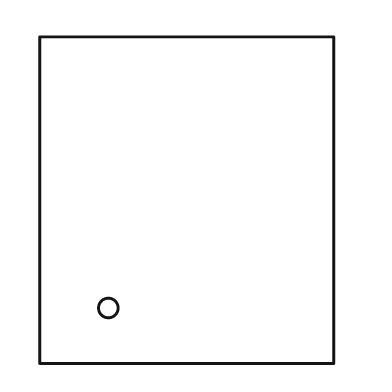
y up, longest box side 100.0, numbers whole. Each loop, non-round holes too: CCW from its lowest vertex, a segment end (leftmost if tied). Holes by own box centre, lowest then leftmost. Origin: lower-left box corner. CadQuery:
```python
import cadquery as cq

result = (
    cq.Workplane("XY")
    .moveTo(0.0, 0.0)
    .lineTo(90.0, 0.0)
    .lineTo(90.0, 100.0)
    .lineTo(0.0, 100.0)
    .close()
    .moveTo(21.0, 17.0)
    .circle(3.0)
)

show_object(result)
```